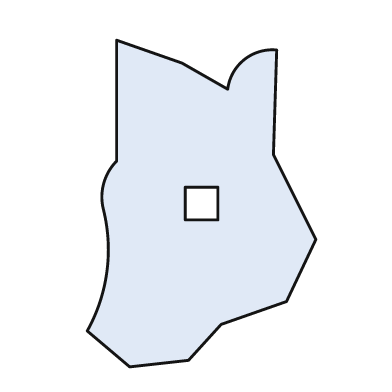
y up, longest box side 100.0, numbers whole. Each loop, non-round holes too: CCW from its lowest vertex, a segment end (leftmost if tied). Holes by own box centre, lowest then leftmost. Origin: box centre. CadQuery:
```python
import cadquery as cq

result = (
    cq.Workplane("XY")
    .moveTo(-22.0, -50.0)
    .lineTo(-4.0, -48.0)
    .lineTo(6.0, -37.0)
    .lineTo(26.0, -30.0)
    .lineTo(35.0, -11.0)
    .lineTo(22.0, 15.0)
    .lineTo(23.0, 47.0)
    .threePointArc((13.0, 44.0), (8.0, 35.0))
    .lineTo(-6.0, 43.0)
    .lineTo(-26.0, 50.0)
    .lineTo(-26.0, 13.0)
    .threePointArc((-30.0, 6.0), (-30.0, -2.0))
    .threePointArc((-29.0, -21.0), (-35.0, -39.0))
    .close()
    .moveTo(-5.0, -5.0)
    .lineTo(5.0, -5.0)
    .lineTo(5.0, 5.0)
    .lineTo(-5.0, 5.0)
    .close()
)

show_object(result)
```